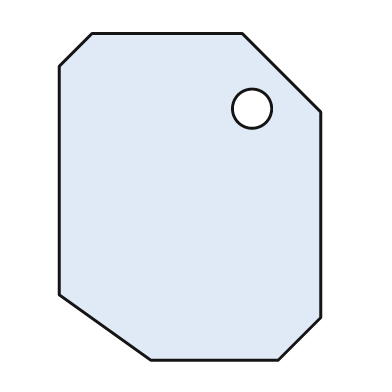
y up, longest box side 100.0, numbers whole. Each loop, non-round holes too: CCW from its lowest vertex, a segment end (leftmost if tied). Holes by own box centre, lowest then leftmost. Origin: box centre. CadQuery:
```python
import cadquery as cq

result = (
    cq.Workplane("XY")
    .moveTo(-12.0, -50.0)
    .lineTo(27.0, -50.0)
    .lineTo(40.0, -37.0)
    .lineTo(40.0, 26.0)
    .lineTo(16.0, 50.0)
    .lineTo(-30.0, 50.0)
    .lineTo(-40.0, 40.0)
    .lineTo(-40.0, -30.0)
    .close()
    .moveTo(19.0, 27.0)
    .circle(6.0)
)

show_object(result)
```